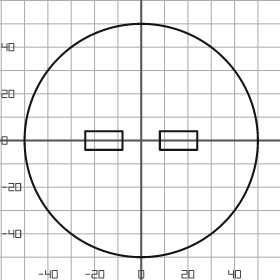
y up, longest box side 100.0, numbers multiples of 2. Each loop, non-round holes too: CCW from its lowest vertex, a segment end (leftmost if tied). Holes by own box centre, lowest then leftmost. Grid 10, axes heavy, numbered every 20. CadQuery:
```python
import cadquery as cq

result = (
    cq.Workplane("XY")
    .moveTo(0.0, 0.0)
    .circle(50.0)
    .moveTo(-24.0, -4.0)
    .lineTo(-8.0, -4.0)
    .lineTo(-8.0, 4.0)
    .lineTo(-24.0, 4.0)
    .close()
    .moveTo(8.0, -4.0)
    .lineTo(24.0, -4.0)
    .lineTo(24.0, 4.0)
    .lineTo(8.0, 4.0)
    .close()
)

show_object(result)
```